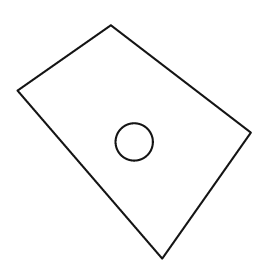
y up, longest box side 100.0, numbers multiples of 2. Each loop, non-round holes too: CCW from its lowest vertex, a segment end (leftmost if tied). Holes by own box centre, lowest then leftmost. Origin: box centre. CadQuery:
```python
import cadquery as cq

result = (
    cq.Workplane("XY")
    .moveTo(12.0, -50.0)
    .lineTo(50.0, 4.0)
    .lineTo(-10.0, 50.0)
    .lineTo(-50.0, 22.0)
    .close()
    .moveTo(0.0, 0.0)
    .circle(8.0)
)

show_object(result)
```